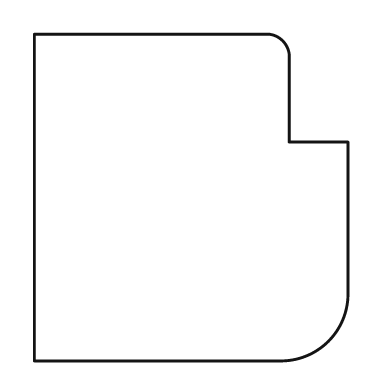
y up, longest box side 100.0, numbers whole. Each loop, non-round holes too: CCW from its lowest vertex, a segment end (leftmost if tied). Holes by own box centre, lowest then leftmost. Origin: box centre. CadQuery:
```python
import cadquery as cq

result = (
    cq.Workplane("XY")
    .moveTo(-48.0, -50.0)
    .lineTo(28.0, -50.0)
    .threePointArc((42.0, -44.0), (48.0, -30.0))
    .lineTo(48.0, 17.0)
    .lineTo(30.0, 17.0)
    .lineTo(30.0, 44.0)
    .threePointArc((28.0, 48.0), (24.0, 50.0))
    .lineTo(-48.0, 50.0)
    .close()
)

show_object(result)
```